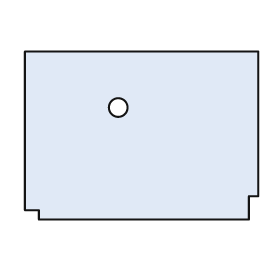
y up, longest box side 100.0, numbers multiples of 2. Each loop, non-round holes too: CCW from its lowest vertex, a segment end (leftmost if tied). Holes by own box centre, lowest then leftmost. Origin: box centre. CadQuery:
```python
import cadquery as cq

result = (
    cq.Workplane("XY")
    .moveTo(-44.0, -36.0)
    .lineTo(46.0, -36.0)
    .lineTo(46.0, -26.0)
    .lineTo(50.0, -26.0)
    .lineTo(50.0, 36.0)
    .lineTo(-50.0, 36.0)
    .lineTo(-50.0, -32.0)
    .lineTo(-44.0, -32.0)
    .close()
    .moveTo(-10.0, 12.0)
    .circle(4.0)
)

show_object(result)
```